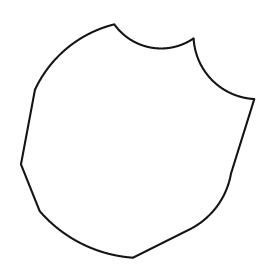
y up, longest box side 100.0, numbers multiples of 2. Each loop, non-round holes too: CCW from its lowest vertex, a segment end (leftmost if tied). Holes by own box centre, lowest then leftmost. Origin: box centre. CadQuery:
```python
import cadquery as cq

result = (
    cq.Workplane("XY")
    .moveTo(-2.0, -50.0)
    .lineTo(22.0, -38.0)
    .threePointArc((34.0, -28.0), (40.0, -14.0))
    .lineTo(50.0, 18.0)
    .threePointArc((32.0, 26.0), (24.0, 44.0))
    .threePointArc((6.0, 40.0), (-10.0, 50.0))
    .threePointArc((-30.0, 40.0), (-44.0, 22.0))
    .lineTo(-50.0, -10.0)
    .lineTo(-42.0, -30.0)
    .threePointArc((-24.0, -44.0), (-2.0, -50.0))
    .close()
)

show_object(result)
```